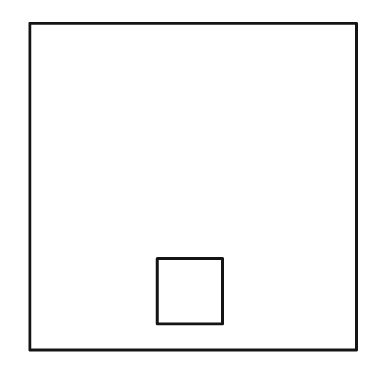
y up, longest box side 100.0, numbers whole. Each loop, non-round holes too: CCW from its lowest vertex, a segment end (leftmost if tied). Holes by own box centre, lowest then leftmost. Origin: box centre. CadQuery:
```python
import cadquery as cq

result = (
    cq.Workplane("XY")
    .moveTo(-50.0, -50.0)
    .lineTo(50.0, -50.0)
    .lineTo(50.0, 50.0)
    .lineTo(-50.0, 50.0)
    .close()
    .moveTo(-11.0, -42.0)
    .lineTo(9.0, -42.0)
    .lineTo(9.0, -22.0)
    .lineTo(-11.0, -22.0)
    .close()
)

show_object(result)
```